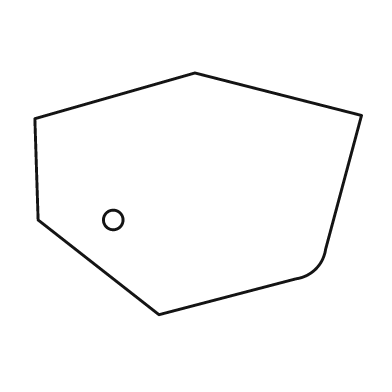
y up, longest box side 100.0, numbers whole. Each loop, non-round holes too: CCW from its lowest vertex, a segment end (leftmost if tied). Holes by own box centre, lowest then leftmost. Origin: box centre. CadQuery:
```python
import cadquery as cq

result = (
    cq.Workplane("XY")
    .moveTo(-12.0, -37.0)
    .lineTo(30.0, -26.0)
    .threePointArc((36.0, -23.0), (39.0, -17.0))
    .lineTo(50.0, 24.0)
    .lineTo(-1.0, 37.0)
    .lineTo(-50.0, 23.0)
    .lineTo(-49.0, -8.0)
    .close()
    .moveTo(-26.0, -8.0)
    .circle(3.0)
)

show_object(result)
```